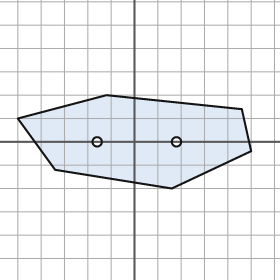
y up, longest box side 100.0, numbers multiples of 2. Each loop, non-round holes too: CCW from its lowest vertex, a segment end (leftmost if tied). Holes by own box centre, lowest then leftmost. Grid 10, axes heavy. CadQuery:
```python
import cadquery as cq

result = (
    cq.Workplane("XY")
    .moveTo(16.0, -20.0)
    .lineTo(50.0, -4.0)
    .lineTo(46.0, 14.0)
    .lineTo(-12.0, 20.0)
    .lineTo(-50.0, 10.0)
    .lineTo(-34.0, -12.0)
    .close()
    .moveTo(-16.0, 0.0)
    .circle(2.0)
    .moveTo(18.0, 0.0)
    .circle(2.0)
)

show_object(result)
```